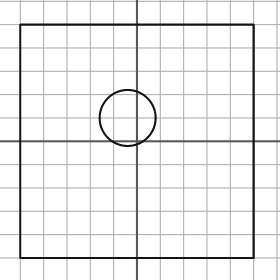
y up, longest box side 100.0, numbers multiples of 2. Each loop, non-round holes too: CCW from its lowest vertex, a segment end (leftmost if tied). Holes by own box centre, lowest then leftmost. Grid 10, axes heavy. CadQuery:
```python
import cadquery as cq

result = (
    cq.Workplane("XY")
    .moveTo(-50.0, -50.0)
    .lineTo(50.0, -50.0)
    .lineTo(50.0, 50.0)
    .lineTo(-50.0, 50.0)
    .close()
    .moveTo(-4.0, 10.0)
    .circle(12.0)
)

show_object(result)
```